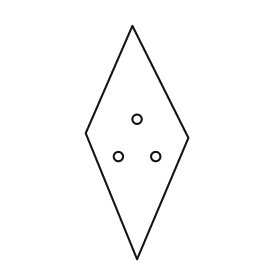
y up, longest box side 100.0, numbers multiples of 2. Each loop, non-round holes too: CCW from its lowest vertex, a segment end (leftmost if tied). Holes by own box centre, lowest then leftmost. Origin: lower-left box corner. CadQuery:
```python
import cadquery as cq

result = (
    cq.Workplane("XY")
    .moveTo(22.0, 0.0)
    .lineTo(44.0, 52.0)
    .lineTo(20.0, 100.0)
    .lineTo(0.0, 54.0)
    .close()
    .moveTo(14.0, 44.0)
    .circle(2.0)
    .moveTo(30.0, 44.0)
    .circle(2.0)
    .moveTo(22.0, 60.0)
    .circle(2.0)
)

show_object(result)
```